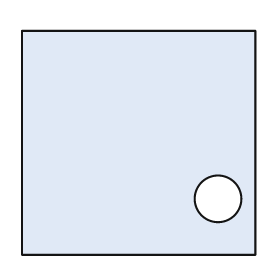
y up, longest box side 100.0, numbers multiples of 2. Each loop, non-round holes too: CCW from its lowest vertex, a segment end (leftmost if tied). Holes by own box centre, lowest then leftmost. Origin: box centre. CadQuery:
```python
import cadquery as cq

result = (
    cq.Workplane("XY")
    .moveTo(-50.0, -48.0)
    .lineTo(50.0, -48.0)
    .lineTo(50.0, 48.0)
    .lineTo(-50.0, 48.0)
    .close()
    .moveTo(34.0, -24.0)
    .circle(10.0)
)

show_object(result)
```